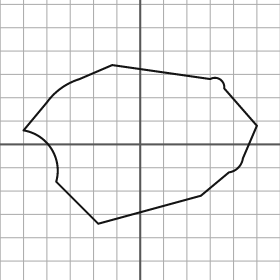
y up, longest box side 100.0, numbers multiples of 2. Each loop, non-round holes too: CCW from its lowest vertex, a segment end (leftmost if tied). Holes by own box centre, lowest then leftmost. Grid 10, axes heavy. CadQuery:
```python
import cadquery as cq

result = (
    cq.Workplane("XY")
    .moveTo(-18.0, -34.0)
    .lineTo(26.0, -22.0)
    .lineTo(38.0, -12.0)
    .threePointArc((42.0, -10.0), (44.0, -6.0))
    .lineTo(50.0, 8.0)
    .lineTo(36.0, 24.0)
    .threePointArc((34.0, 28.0), (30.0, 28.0))
    .lineTo(-12.0, 34.0)
    .lineTo(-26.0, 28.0)
    .threePointArc((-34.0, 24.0), (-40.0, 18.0))
    .lineTo(-50.0, 6.0)
    .threePointArc((-38.0, -2.0), (-36.0, -16.0))
    .close()
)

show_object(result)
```